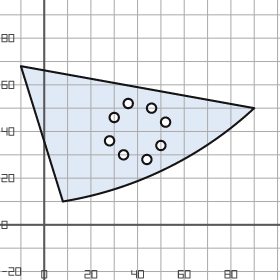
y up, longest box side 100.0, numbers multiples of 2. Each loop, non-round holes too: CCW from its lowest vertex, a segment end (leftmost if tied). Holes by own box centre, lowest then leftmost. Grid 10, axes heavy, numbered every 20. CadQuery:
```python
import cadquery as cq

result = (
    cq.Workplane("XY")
    .moveTo(8.0, 10.0)
    .threePointArc((52.0, 24.0), (90.0, 50.0))
    .lineTo(-10.0, 68.0)
    .close()
    .moveTo(44.0, 28.0)
    .circle(2.0)
    .moveTo(34.0, 30.0)
    .circle(2.0)
    .moveTo(50.0, 34.0)
    .circle(2.0)
    .moveTo(28.0, 36.0)
    .circle(2.0)
    .moveTo(52.0, 44.0)
    .circle(2.0)
    .moveTo(30.0, 46.0)
    .circle(2.0)
    .moveTo(46.0, 50.0)
    .circle(2.0)
    .moveTo(36.0, 52.0)
    .circle(2.0)
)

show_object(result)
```